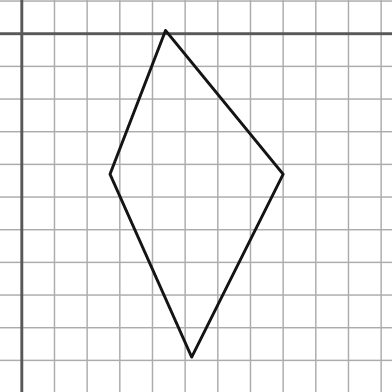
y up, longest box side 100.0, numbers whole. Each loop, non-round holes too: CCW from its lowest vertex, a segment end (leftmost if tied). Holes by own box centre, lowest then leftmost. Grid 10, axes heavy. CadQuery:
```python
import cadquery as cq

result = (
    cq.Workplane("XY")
    .moveTo(52.0, -99.0)
    .lineTo(80.0, -43.0)
    .lineTo(44.0, 1.0)
    .lineTo(27.0, -43.0)
    .close()
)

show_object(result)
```